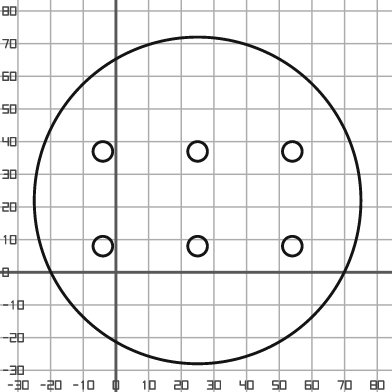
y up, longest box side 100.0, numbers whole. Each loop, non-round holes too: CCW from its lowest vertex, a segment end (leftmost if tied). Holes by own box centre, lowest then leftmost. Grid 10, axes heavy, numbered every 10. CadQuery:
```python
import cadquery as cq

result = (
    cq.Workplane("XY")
    .moveTo(25.0, 22.0)
    .circle(50.0)
    .moveTo(-4.0, 8.0)
    .circle(3.0)
    .moveTo(25.0, 8.0)
    .circle(3.0)
    .moveTo(54.0, 8.0)
    .circle(3.0)
    .moveTo(-4.0, 37.0)
    .circle(3.0)
    .moveTo(25.0, 37.0)
    .circle(3.0)
    .moveTo(54.0, 37.0)
    .circle(3.0)
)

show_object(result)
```